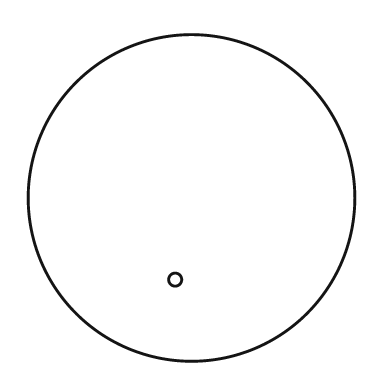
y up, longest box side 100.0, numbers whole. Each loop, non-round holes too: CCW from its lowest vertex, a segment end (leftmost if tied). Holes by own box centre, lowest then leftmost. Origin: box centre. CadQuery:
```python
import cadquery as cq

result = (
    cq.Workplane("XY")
    .moveTo(0.0, 0.0)
    .circle(50.0)
    .moveTo(-5.0, -25.0)
    .circle(2.0)
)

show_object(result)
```